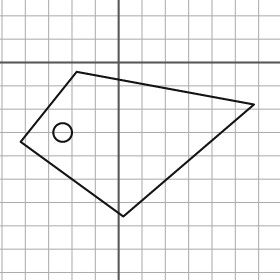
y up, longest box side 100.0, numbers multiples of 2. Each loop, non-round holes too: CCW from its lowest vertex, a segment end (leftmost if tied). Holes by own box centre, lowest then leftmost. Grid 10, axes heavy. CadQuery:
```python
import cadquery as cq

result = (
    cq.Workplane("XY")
    .moveTo(2.0, -66.0)
    .lineTo(58.0, -18.0)
    .lineTo(-18.0, -4.0)
    .lineTo(-42.0, -34.0)
    .close()
    .moveTo(-24.0, -30.0)
    .circle(4.0)
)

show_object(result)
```